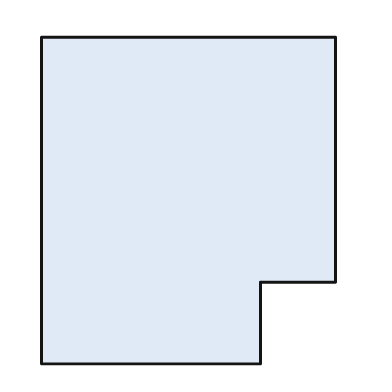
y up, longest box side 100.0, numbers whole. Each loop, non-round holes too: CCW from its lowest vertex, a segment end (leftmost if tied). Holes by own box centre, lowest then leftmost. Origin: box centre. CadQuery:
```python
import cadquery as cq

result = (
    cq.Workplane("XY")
    .moveTo(-45.0, -50.0)
    .lineTo(22.0, -50.0)
    .lineTo(22.0, -25.0)
    .lineTo(45.0, -25.0)
    .lineTo(45.0, 50.0)
    .lineTo(-45.0, 50.0)
    .close()
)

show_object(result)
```